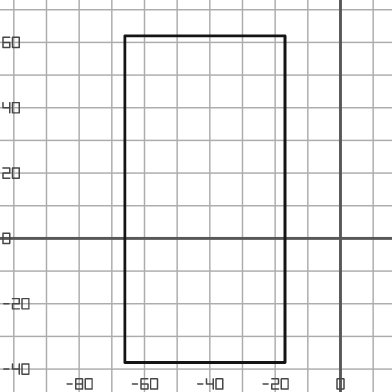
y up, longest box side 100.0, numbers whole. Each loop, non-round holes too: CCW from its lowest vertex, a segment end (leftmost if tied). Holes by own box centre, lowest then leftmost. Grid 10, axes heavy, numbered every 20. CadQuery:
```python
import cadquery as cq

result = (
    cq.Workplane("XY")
    .moveTo(-66.0, -38.0)
    .lineTo(-17.0, -38.0)
    .lineTo(-17.0, 62.0)
    .lineTo(-66.0, 62.0)
    .close()
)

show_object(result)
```